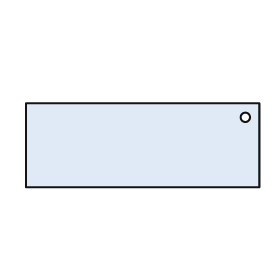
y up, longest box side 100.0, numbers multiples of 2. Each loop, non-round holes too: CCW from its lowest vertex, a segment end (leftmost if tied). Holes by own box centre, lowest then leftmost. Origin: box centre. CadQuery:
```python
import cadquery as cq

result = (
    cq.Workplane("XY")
    .moveTo(-50.0, -18.0)
    .lineTo(50.0, -18.0)
    .lineTo(50.0, 18.0)
    .lineTo(-50.0, 18.0)
    .close()
    .moveTo(44.0, 12.0)
    .circle(2.0)
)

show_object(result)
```